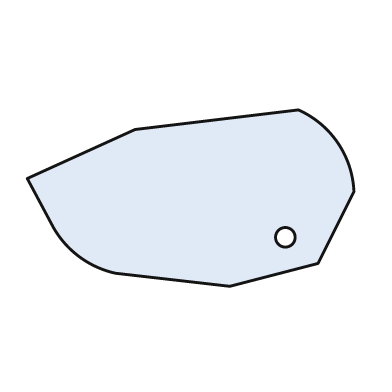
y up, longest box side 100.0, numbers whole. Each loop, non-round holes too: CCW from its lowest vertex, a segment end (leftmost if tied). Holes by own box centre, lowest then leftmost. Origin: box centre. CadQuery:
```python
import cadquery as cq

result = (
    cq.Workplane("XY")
    .moveTo(12.0, -27.0)
    .lineTo(39.0, -20.0)
    .lineTo(50.0, 2.0)
    .threePointArc((45.0, 17.0), (33.0, 27.0))
    .lineTo(-17.0, 21.0)
    .lineTo(-50.0, 6.0)
    .lineTo(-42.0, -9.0)
    .threePointArc((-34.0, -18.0), (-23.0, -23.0))
    .close()
    .moveTo(29.0, -12.0)
    .circle(3.0)
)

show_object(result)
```